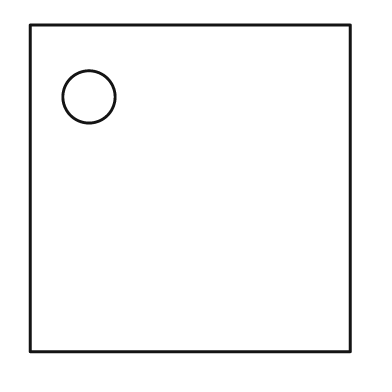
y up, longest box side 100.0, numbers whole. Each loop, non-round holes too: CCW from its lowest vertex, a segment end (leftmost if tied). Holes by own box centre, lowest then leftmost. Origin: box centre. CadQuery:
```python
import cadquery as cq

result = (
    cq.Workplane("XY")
    .moveTo(-49.0, -50.0)
    .lineTo(49.0, -50.0)
    .lineTo(49.0, 50.0)
    .lineTo(-49.0, 50.0)
    .close()
    .moveTo(-31.0, 28.0)
    .circle(8.0)
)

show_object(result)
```